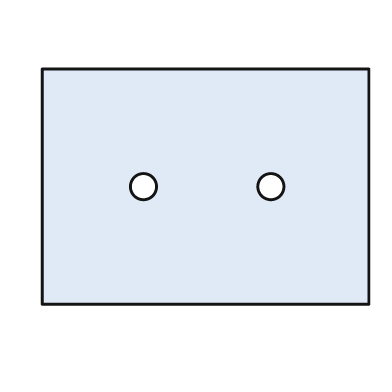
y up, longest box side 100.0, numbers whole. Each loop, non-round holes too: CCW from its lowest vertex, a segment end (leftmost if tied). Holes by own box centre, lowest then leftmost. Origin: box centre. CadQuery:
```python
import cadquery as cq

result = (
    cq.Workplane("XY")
    .moveTo(-50.0, -36.0)
    .lineTo(50.0, -36.0)
    .lineTo(50.0, 36.0)
    .lineTo(-50.0, 36.0)
    .close()
    .moveTo(-19.0, 0.0)
    .circle(4.0)
    .moveTo(20.0, 0.0)
    .circle(4.0)
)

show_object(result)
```